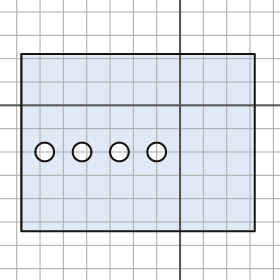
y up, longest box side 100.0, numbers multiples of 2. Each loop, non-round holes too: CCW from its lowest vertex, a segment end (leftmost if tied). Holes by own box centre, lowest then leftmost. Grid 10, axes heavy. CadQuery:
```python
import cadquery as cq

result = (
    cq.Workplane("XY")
    .moveTo(-68.0, -54.0)
    .lineTo(32.0, -54.0)
    .lineTo(32.0, 22.0)
    .lineTo(-68.0, 22.0)
    .close()
    .moveTo(-58.0, -20.0)
    .circle(4.0)
    .moveTo(-42.0, -20.0)
    .circle(4.0)
    .moveTo(-26.0, -20.0)
    .circle(4.0)
    .moveTo(-10.0, -20.0)
    .circle(4.0)
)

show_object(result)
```